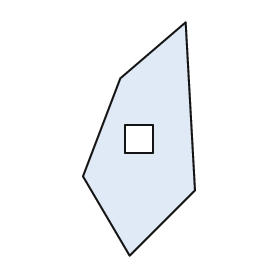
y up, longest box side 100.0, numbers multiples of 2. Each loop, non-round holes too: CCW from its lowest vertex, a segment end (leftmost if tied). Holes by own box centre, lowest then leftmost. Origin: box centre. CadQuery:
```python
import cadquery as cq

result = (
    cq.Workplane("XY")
    .moveTo(-4.0, -50.0)
    .lineTo(24.0, -22.0)
    .lineTo(20.0, 50.0)
    .lineTo(-8.0, 26.0)
    .lineTo(-24.0, -16.0)
    .close()
    .moveTo(-6.0, -6.0)
    .lineTo(6.0, -6.0)
    .lineTo(6.0, 6.0)
    .lineTo(-6.0, 6.0)
    .close()
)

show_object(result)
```